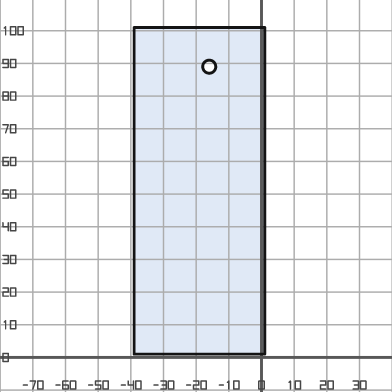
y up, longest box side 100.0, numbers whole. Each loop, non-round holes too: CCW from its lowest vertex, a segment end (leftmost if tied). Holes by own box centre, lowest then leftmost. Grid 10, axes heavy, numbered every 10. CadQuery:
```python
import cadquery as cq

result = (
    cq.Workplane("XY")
    .moveTo(-39.0, 1.0)
    .lineTo(1.0, 1.0)
    .lineTo(1.0, 101.0)
    .lineTo(-39.0, 101.0)
    .close()
    .moveTo(-16.0, 89.0)
    .circle(2.0)
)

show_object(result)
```